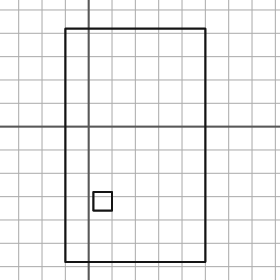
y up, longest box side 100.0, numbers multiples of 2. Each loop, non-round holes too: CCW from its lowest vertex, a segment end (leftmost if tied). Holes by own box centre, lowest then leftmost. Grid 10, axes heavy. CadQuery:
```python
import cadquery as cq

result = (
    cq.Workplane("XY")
    .moveTo(-10.0, -58.0)
    .lineTo(50.0, -58.0)
    .lineTo(50.0, 42.0)
    .lineTo(-10.0, 42.0)
    .close()
    .moveTo(2.0, -36.0)
    .lineTo(10.0, -36.0)
    .lineTo(10.0, -28.0)
    .lineTo(2.0, -28.0)
    .close()
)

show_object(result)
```